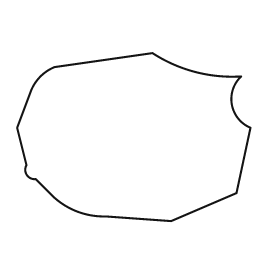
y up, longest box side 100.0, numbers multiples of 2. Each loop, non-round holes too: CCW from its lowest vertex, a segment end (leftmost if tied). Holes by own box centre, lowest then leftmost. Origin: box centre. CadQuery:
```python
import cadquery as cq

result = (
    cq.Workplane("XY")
    .moveTo(16.0, -36.0)
    .lineTo(44.0, -24.0)
    .lineTo(50.0, 4.0)
    .threePointArc((42.0, 14.0), (46.0, 26.0))
    .threePointArc((26.0, 28.0), (8.0, 36.0))
    .lineTo(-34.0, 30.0)
    .threePointArc((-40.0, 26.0), (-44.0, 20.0))
    .lineTo(-50.0, 4.0)
    .lineTo(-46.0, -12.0)
    .threePointArc((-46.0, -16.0), (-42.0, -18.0))
    .lineTo(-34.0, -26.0)
    .threePointArc((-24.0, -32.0), (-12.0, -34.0))
    .close()
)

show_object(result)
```